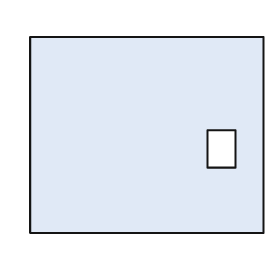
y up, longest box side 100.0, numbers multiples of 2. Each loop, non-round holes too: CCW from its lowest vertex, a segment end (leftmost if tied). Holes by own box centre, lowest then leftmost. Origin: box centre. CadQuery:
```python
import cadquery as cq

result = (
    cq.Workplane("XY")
    .moveTo(-50.0, -42.0)
    .lineTo(50.0, -42.0)
    .lineTo(50.0, 42.0)
    .lineTo(-50.0, 42.0)
    .close()
    .moveTo(26.0, -14.0)
    .lineTo(38.0, -14.0)
    .lineTo(38.0, 2.0)
    .lineTo(26.0, 2.0)
    .close()
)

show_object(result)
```